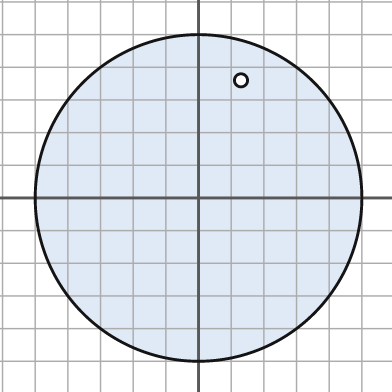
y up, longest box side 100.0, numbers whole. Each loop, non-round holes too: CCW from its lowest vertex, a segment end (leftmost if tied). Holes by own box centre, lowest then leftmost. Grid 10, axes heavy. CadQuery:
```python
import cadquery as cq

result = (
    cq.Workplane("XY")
    .moveTo(0.0, 0.0)
    .circle(50.0)
    .moveTo(13.0, 36.0)
    .circle(2.0)
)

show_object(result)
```